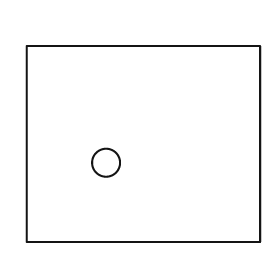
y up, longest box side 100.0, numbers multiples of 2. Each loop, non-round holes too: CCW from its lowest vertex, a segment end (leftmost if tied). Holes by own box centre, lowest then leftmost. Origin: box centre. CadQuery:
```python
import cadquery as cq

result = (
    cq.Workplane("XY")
    .moveTo(-50.0, -42.0)
    .lineTo(50.0, -42.0)
    .lineTo(50.0, 42.0)
    .lineTo(-50.0, 42.0)
    .close()
    .moveTo(-16.0, -8.0)
    .circle(6.0)
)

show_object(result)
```